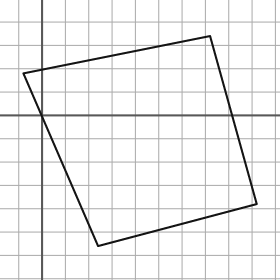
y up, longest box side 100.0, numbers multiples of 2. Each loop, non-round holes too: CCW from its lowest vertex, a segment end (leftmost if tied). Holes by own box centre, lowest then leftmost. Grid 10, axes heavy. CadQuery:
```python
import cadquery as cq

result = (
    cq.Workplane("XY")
    .moveTo(24.0, -56.0)
    .lineTo(92.0, -38.0)
    .lineTo(72.0, 34.0)
    .lineTo(-8.0, 18.0)
    .close()
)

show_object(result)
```